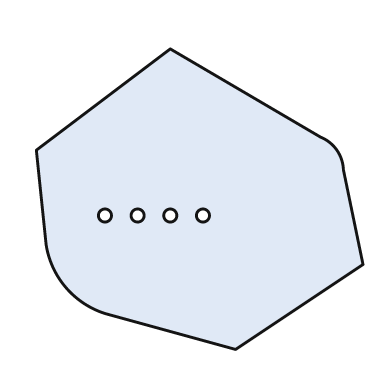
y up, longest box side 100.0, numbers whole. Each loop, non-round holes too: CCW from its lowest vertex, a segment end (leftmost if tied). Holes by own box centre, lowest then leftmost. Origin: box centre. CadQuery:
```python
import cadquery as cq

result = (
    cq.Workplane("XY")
    .moveTo(11.0, -46.0)
    .lineTo(50.0, -20.0)
    .lineTo(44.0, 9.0)
    .threePointArc((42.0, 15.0), (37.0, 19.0))
    .lineTo(-9.0, 46.0)
    .lineTo(-50.0, 15.0)
    .lineTo(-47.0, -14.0)
    .threePointArc((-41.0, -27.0), (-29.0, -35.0))
    .close()
    .moveTo(-29.0, -5.0)
    .circle(2.0)
    .moveTo(-19.0, -5.0)
    .circle(2.0)
    .moveTo(-9.0, -5.0)
    .circle(2.0)
    .moveTo(1.0, -5.0)
    .circle(2.0)
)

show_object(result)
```